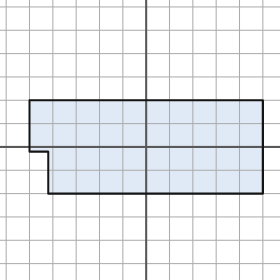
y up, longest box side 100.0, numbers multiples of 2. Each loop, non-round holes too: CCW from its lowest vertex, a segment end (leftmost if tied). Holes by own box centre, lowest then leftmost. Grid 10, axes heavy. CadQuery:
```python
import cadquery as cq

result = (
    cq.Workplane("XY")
    .moveTo(-42.0, -20.0)
    .lineTo(50.0, -20.0)
    .lineTo(50.0, 20.0)
    .lineTo(-50.0, 20.0)
    .lineTo(-50.0, -2.0)
    .lineTo(-42.0, -2.0)
    .close()
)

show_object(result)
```